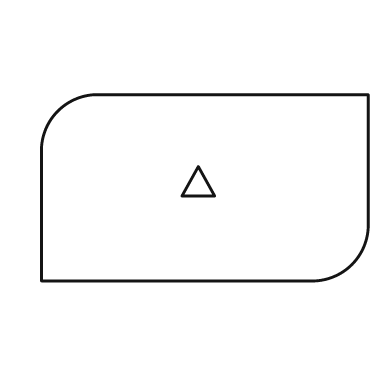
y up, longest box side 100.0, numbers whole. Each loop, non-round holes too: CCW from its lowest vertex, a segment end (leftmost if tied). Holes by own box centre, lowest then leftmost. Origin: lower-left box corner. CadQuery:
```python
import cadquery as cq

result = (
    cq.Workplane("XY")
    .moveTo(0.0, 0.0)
    .lineTo(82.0, 0.0)
    .threePointArc((95.0, 5.0), (100.0, 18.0))
    .lineTo(100.0, 57.0)
    .lineTo(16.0, 57.0)
    .threePointArc((5.0, 52.0), (0.0, 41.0))
    .close()
    .moveTo(43.0, 26.0)
    .lineTo(53.0, 26.0)
    .lineTo(48.0, 35.0)
    .close()
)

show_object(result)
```